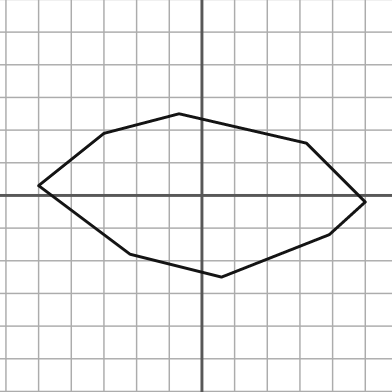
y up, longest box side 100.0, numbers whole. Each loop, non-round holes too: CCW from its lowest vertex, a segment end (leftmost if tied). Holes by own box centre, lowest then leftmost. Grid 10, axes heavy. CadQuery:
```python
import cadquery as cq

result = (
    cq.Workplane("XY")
    .moveTo(6.0, -25.0)
    .lineTo(39.0, -12.0)
    .lineTo(50.0, -2.0)
    .lineTo(32.0, 16.0)
    .lineTo(-7.0, 25.0)
    .lineTo(-30.0, 19.0)
    .lineTo(-50.0, 3.0)
    .lineTo(-22.0, -18.0)
    .close()
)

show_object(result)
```